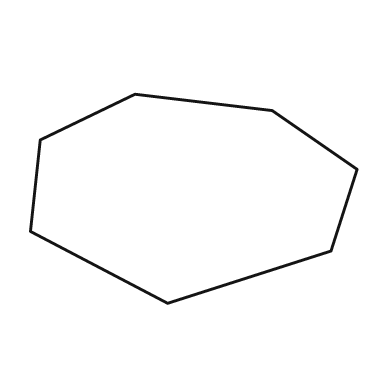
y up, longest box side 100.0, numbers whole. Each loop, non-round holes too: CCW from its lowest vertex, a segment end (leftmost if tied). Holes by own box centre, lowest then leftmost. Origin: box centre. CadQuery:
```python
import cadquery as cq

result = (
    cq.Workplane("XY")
    .moveTo(-8.0, -32.0)
    .lineTo(42.0, -16.0)
    .lineTo(50.0, 9.0)
    .lineTo(24.0, 27.0)
    .lineTo(-18.0, 32.0)
    .lineTo(-47.0, 18.0)
    .lineTo(-50.0, -10.0)
    .close()
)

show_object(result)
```